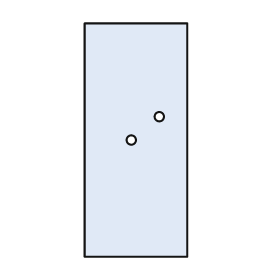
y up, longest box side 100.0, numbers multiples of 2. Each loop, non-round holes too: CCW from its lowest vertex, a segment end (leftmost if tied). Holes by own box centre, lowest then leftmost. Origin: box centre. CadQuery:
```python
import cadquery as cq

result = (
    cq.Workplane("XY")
    .moveTo(-22.0, -50.0)
    .lineTo(22.0, -50.0)
    .lineTo(22.0, 50.0)
    .lineTo(-22.0, 50.0)
    .close()
    .moveTo(-2.0, 0.0)
    .circle(2.0)
    .moveTo(10.0, 10.0)
    .circle(2.0)
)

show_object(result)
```